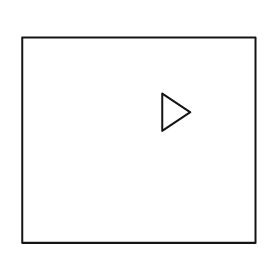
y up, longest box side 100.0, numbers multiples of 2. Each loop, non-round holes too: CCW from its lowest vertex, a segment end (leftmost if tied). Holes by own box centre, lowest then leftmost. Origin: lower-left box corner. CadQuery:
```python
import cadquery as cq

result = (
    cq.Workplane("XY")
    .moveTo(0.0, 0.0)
    .lineTo(100.0, 0.0)
    .lineTo(100.0, 88.0)
    .lineTo(0.0, 88.0)
    .close()
    .moveTo(60.0, 48.0)
    .lineTo(72.0, 56.0)
    .lineTo(60.0, 64.0)
    .close()
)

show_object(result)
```